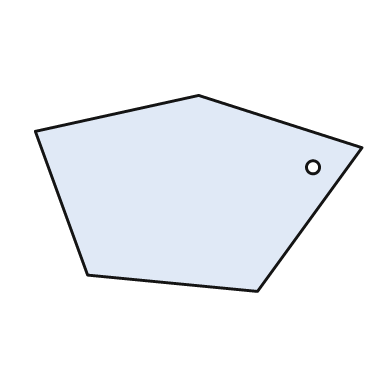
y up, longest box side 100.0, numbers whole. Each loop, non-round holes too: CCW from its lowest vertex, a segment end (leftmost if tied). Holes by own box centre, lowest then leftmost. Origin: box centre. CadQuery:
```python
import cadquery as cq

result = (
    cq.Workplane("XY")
    .moveTo(18.0, -30.0)
    .lineTo(50.0, 14.0)
    .lineTo(0.0, 30.0)
    .lineTo(-50.0, 19.0)
    .lineTo(-34.0, -25.0)
    .close()
    .moveTo(35.0, 8.0)
    .circle(2.0)
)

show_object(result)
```